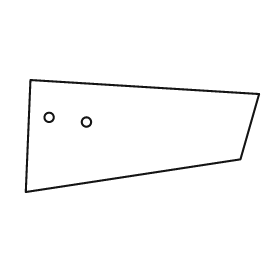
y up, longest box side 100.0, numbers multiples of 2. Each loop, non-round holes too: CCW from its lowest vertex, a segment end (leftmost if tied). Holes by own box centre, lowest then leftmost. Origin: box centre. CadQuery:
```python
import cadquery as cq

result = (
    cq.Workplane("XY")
    .moveTo(-50.0, -24.0)
    .lineTo(42.0, -10.0)
    .lineTo(50.0, 18.0)
    .lineTo(-48.0, 24.0)
    .close()
    .moveTo(-24.0, 6.0)
    .circle(2.0)
    .moveTo(-40.0, 8.0)
    .circle(2.0)
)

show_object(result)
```